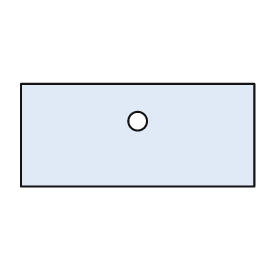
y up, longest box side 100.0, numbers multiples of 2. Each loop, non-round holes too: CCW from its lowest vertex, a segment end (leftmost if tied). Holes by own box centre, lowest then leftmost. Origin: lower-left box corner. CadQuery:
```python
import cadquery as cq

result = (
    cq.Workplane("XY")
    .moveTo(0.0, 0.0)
    .lineTo(100.0, 0.0)
    .lineTo(100.0, 44.0)
    .lineTo(0.0, 44.0)
    .close()
    .moveTo(50.0, 28.0)
    .circle(4.0)
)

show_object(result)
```